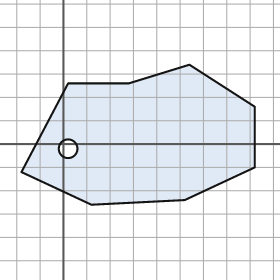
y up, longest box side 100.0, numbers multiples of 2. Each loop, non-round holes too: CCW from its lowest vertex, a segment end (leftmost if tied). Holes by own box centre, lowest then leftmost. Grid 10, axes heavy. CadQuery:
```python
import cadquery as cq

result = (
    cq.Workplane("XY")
    .moveTo(12.0, -26.0)
    .lineTo(52.0, -24.0)
    .lineTo(82.0, -10.0)
    .lineTo(82.0, 16.0)
    .lineTo(54.0, 34.0)
    .lineTo(28.0, 26.0)
    .lineTo(2.0, 26.0)
    .lineTo(-18.0, -12.0)
    .close()
    .moveTo(2.0, -2.0)
    .circle(4.0)
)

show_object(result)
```